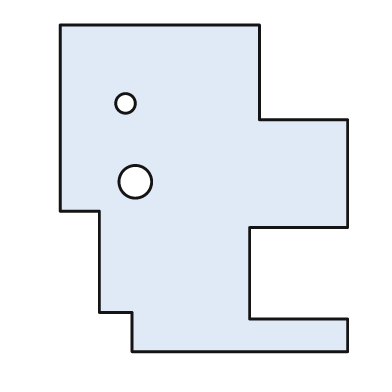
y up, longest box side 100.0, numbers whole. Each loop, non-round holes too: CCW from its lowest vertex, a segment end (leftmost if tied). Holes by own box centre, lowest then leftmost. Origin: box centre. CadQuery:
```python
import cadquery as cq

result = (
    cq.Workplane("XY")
    .moveTo(-22.0, -50.0)
    .lineTo(44.0, -50.0)
    .lineTo(44.0, -40.0)
    .lineTo(14.0, -40.0)
    .lineTo(14.0, -12.0)
    .lineTo(44.0, -12.0)
    .lineTo(44.0, 21.0)
    .lineTo(17.0, 21.0)
    .lineTo(17.0, 50.0)
    .lineTo(-44.0, 50.0)
    .lineTo(-44.0, -7.0)
    .lineTo(-32.0, -7.0)
    .lineTo(-32.0, -38.0)
    .lineTo(-22.0, -38.0)
    .close()
    .moveTo(-21.0, 2.0)
    .circle(5.0)
    .moveTo(-24.0, 26.0)
    .circle(3.0)
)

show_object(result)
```